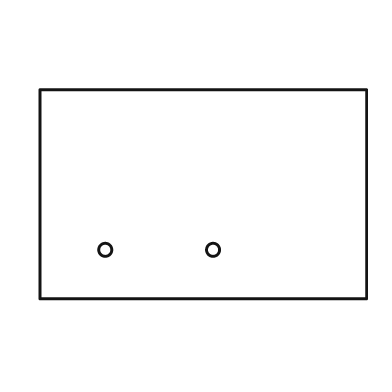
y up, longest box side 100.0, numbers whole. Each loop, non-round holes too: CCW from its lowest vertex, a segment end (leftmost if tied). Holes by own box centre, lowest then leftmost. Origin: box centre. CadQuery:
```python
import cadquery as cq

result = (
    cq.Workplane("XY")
    .moveTo(-50.0, -32.0)
    .lineTo(50.0, -32.0)
    .lineTo(50.0, 32.0)
    .lineTo(-50.0, 32.0)
    .close()
    .moveTo(-30.0, -17.0)
    .circle(2.0)
    .moveTo(3.0, -17.0)
    .circle(2.0)
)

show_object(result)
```